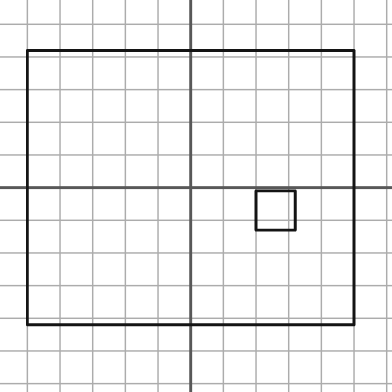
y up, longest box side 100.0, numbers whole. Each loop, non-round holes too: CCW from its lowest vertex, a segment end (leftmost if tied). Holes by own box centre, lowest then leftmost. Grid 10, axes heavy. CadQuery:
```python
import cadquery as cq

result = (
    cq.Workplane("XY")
    .moveTo(-50.0, -42.0)
    .lineTo(50.0, -42.0)
    .lineTo(50.0, 42.0)
    .lineTo(-50.0, 42.0)
    .close()
    .moveTo(20.0, -13.0)
    .lineTo(32.0, -13.0)
    .lineTo(32.0, -1.0)
    .lineTo(20.0, -1.0)
    .close()
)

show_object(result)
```